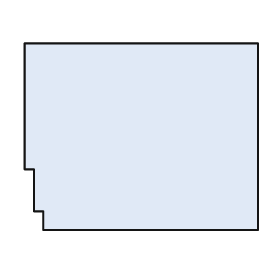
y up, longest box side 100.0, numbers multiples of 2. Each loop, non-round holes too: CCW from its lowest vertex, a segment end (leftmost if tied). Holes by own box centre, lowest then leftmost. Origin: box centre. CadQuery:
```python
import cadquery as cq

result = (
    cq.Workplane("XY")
    .moveTo(-42.0, -40.0)
    .lineTo(50.0, -40.0)
    .lineTo(50.0, 40.0)
    .lineTo(-50.0, 40.0)
    .lineTo(-50.0, -14.0)
    .lineTo(-46.0, -14.0)
    .lineTo(-46.0, -32.0)
    .lineTo(-42.0, -32.0)
    .close()
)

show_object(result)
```